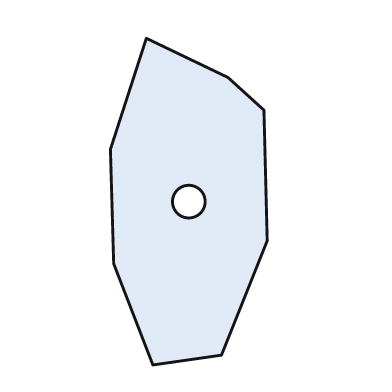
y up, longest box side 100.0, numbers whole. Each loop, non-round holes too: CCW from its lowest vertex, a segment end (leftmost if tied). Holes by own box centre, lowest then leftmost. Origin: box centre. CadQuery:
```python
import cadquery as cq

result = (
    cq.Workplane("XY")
    .moveTo(-11.0, -50.0)
    .lineTo(10.0, -47.0)
    .lineTo(24.0, -12.0)
    .lineTo(23.0, 28.0)
    .lineTo(12.0, 38.0)
    .lineTo(-13.0, 50.0)
    .lineTo(-24.0, 16.0)
    .lineTo(-23.0, -19.0)
    .close()
    .moveTo(0.0, 0.0)
    .circle(5.0)
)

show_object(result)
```